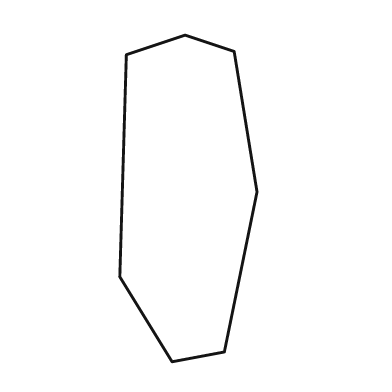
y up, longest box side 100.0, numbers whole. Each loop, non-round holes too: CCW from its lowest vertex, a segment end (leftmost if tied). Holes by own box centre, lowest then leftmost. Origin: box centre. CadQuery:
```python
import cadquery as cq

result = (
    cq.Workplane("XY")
    .moveTo(-5.0, -50.0)
    .lineTo(11.0, -47.0)
    .lineTo(21.0, 2.0)
    .lineTo(14.0, 45.0)
    .lineTo(-1.0, 50.0)
    .lineTo(-19.0, 44.0)
    .lineTo(-21.0, -24.0)
    .close()
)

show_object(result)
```